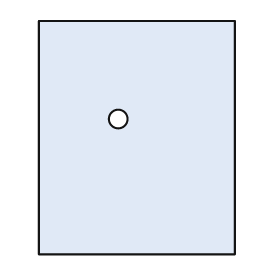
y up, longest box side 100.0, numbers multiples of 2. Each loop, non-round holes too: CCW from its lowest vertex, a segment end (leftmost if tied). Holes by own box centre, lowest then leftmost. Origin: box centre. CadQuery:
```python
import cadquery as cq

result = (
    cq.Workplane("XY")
    .moveTo(-42.0, -50.0)
    .lineTo(42.0, -50.0)
    .lineTo(42.0, 50.0)
    .lineTo(-42.0, 50.0)
    .close()
    .moveTo(-8.0, 8.0)
    .circle(4.0)
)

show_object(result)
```